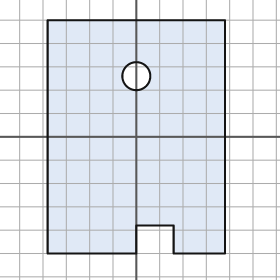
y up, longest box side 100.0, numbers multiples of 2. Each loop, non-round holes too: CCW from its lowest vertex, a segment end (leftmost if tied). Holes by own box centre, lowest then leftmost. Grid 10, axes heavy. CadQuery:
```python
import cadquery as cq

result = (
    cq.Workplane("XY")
    .moveTo(-38.0, -50.0)
    .lineTo(0.0, -50.0)
    .lineTo(0.0, -38.0)
    .lineTo(16.0, -38.0)
    .lineTo(16.0, -50.0)
    .lineTo(38.0, -50.0)
    .lineTo(38.0, 50.0)
    .lineTo(-38.0, 50.0)
    .close()
    .moveTo(0.0, 26.0)
    .circle(6.0)
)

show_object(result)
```